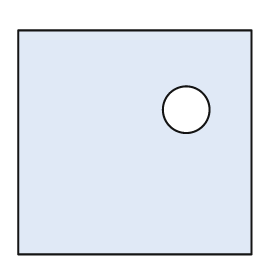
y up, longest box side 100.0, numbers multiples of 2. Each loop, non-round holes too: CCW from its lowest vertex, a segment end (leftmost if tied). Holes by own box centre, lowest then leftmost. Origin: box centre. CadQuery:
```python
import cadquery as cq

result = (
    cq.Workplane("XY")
    .moveTo(-50.0, -48.0)
    .lineTo(50.0, -48.0)
    .lineTo(50.0, 48.0)
    .lineTo(-50.0, 48.0)
    .close()
    .moveTo(22.0, 14.0)
    .circle(10.0)
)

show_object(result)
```